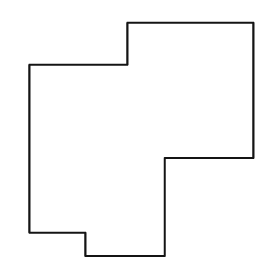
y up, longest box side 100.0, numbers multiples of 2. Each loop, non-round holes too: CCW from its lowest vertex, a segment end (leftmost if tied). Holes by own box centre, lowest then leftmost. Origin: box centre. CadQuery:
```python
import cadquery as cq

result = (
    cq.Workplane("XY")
    .moveTo(-24.0, -50.0)
    .lineTo(10.0, -50.0)
    .lineTo(10.0, -8.0)
    .lineTo(48.0, -8.0)
    .lineTo(48.0, 50.0)
    .lineTo(-6.0, 50.0)
    .lineTo(-6.0, 32.0)
    .lineTo(-48.0, 32.0)
    .lineTo(-48.0, -40.0)
    .lineTo(-24.0, -40.0)
    .close()
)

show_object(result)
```